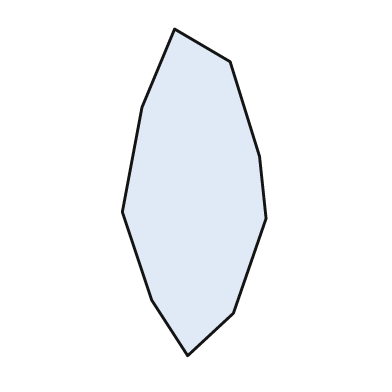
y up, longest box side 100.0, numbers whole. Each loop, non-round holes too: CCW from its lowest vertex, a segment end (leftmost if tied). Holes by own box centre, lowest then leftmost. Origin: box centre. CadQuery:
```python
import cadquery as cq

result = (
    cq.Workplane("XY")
    .moveTo(-2.0, -50.0)
    .lineTo(12.0, -37.0)
    .lineTo(22.0, -8.0)
    .lineTo(20.0, 11.0)
    .lineTo(11.0, 40.0)
    .lineTo(-6.0, 50.0)
    .lineTo(-16.0, 26.0)
    .lineTo(-22.0, -6.0)
    .lineTo(-13.0, -33.0)
    .close()
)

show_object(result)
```